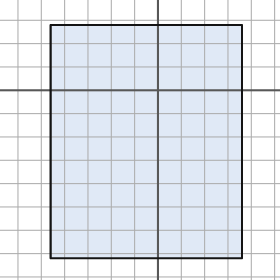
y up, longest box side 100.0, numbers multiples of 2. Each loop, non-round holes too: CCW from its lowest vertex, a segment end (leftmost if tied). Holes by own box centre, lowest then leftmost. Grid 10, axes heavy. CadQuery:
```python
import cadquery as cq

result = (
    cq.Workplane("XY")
    .moveTo(-46.0, -72.0)
    .lineTo(36.0, -72.0)
    .lineTo(36.0, 28.0)
    .lineTo(-46.0, 28.0)
    .close()
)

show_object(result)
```